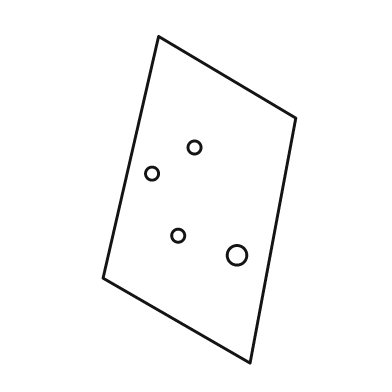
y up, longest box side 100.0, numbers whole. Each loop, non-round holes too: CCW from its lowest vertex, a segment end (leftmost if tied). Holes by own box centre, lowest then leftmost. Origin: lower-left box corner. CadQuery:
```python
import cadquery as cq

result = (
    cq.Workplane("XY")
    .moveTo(45.0, 0.0)
    .lineTo(59.0, 75.0)
    .lineTo(17.0, 100.0)
    .lineTo(0.0, 26.0)
    .close()
    .moveTo(41.0, 33.0)
    .circle(3.0)
    .moveTo(23.0, 39.0)
    .circle(2.0)
    .moveTo(15.0, 58.0)
    .circle(2.0)
    .moveTo(28.0, 66.0)
    .circle(2.0)
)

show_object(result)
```